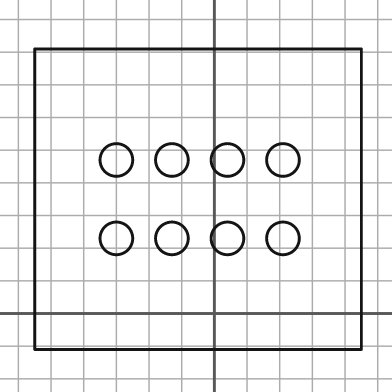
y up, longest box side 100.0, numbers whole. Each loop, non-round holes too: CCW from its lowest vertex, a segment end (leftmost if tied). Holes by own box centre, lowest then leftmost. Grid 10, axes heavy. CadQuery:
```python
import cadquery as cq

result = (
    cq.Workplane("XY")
    .moveTo(-55.0, -11.0)
    .lineTo(45.0, -11.0)
    .lineTo(45.0, 81.0)
    .lineTo(-55.0, 81.0)
    .close()
    .moveTo(-30.0, 23.0)
    .circle(5.0)
    .moveTo(-13.0, 23.0)
    .circle(5.0)
    .moveTo(4.0, 23.0)
    .circle(5.0)
    .moveTo(21.0, 23.0)
    .circle(5.0)
    .moveTo(-30.0, 47.0)
    .circle(5.0)
    .moveTo(-13.0, 47.0)
    .circle(5.0)
    .moveTo(4.0, 47.0)
    .circle(5.0)
    .moveTo(21.0, 47.0)
    .circle(5.0)
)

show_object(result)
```